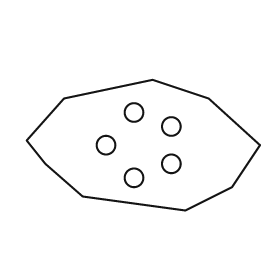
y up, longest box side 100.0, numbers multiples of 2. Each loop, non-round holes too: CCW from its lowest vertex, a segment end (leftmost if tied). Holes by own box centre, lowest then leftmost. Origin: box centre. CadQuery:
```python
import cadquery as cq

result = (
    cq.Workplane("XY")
    .moveTo(18.0, -28.0)
    .lineTo(38.0, -18.0)
    .lineTo(50.0, 0.0)
    .lineTo(28.0, 20.0)
    .lineTo(4.0, 28.0)
    .lineTo(-34.0, 20.0)
    .lineTo(-50.0, 2.0)
    .lineTo(-42.0, -8.0)
    .lineTo(-26.0, -22.0)
    .close()
    .moveTo(-4.0, -14.0)
    .circle(4.0)
    .moveTo(12.0, -8.0)
    .circle(4.0)
    .moveTo(-16.0, 0.0)
    .circle(4.0)
    .moveTo(12.0, 8.0)
    .circle(4.0)
    .moveTo(-4.0, 14.0)
    .circle(4.0)
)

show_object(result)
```